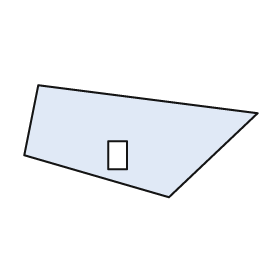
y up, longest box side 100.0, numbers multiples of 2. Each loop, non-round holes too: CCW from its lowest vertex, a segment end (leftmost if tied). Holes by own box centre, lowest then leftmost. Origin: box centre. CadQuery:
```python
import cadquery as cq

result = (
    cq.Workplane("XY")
    .moveTo(12.0, -24.0)
    .lineTo(50.0, 12.0)
    .lineTo(-44.0, 24.0)
    .lineTo(-50.0, -6.0)
    .close()
    .moveTo(-14.0, -12.0)
    .lineTo(-6.0, -12.0)
    .lineTo(-6.0, 0.0)
    .lineTo(-14.0, 0.0)
    .close()
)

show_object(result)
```